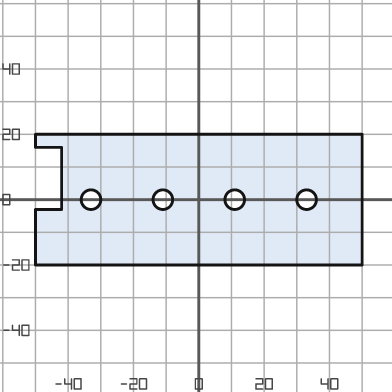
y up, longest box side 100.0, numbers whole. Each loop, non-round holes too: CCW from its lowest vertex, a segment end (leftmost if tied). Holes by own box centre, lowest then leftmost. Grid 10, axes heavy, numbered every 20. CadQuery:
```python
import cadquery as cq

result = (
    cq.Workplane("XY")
    .moveTo(-50.0, -20.0)
    .lineTo(50.0, -20.0)
    .lineTo(50.0, 20.0)
    .lineTo(-50.0, 20.0)
    .lineTo(-50.0, 16.0)
    .lineTo(-42.0, 16.0)
    .lineTo(-42.0, -3.0)
    .lineTo(-50.0, -3.0)
    .close()
    .moveTo(-33.0, 0.0)
    .circle(3.0)
    .moveTo(-11.0, 0.0)
    .circle(3.0)
    .moveTo(11.0, 0.0)
    .circle(3.0)
    .moveTo(33.0, 0.0)
    .circle(3.0)
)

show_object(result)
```